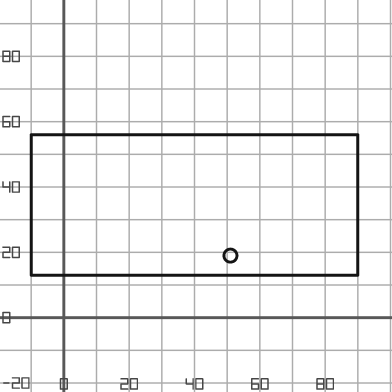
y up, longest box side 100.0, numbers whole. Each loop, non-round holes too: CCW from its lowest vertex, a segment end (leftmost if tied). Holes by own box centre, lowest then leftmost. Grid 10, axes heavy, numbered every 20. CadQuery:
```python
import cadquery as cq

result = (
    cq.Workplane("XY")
    .moveTo(-10.0, 13.0)
    .lineTo(90.0, 13.0)
    .lineTo(90.0, 56.0)
    .lineTo(-10.0, 56.0)
    .close()
    .moveTo(51.0, 19.0)
    .circle(2.0)
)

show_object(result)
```